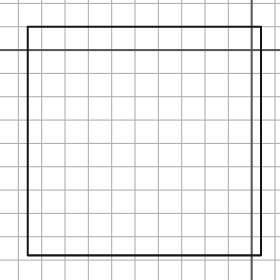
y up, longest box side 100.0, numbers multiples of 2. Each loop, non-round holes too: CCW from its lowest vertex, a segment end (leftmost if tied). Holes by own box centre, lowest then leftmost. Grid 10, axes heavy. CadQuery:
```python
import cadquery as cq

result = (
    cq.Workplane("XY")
    .moveTo(-96.0, -88.0)
    .lineTo(4.0, -88.0)
    .lineTo(4.0, 10.0)
    .lineTo(-96.0, 10.0)
    .close()
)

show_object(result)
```